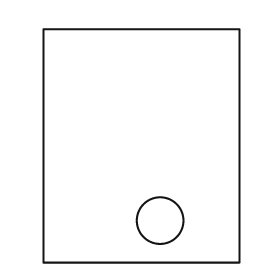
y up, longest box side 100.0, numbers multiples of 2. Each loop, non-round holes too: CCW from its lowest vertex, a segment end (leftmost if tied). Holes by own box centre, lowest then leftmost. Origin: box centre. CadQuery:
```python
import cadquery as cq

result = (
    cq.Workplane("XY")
    .moveTo(-42.0, -50.0)
    .lineTo(42.0, -50.0)
    .lineTo(42.0, 50.0)
    .lineTo(-42.0, 50.0)
    .close()
    .moveTo(8.0, -32.0)
    .circle(10.0)
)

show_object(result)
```